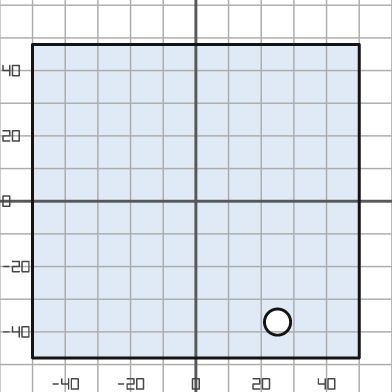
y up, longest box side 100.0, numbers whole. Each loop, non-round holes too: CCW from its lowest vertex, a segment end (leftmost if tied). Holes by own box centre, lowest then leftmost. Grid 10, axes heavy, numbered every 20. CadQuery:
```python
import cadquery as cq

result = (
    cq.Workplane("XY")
    .moveTo(-50.0, -48.0)
    .lineTo(50.0, -48.0)
    .lineTo(50.0, 48.0)
    .lineTo(-50.0, 48.0)
    .close()
    .moveTo(25.0, -37.0)
    .circle(4.0)
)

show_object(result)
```